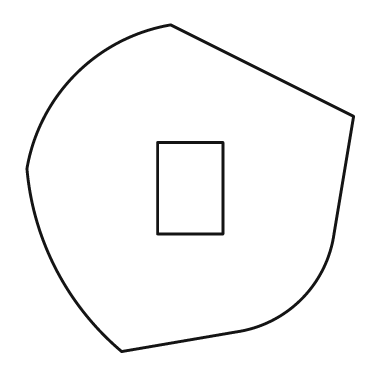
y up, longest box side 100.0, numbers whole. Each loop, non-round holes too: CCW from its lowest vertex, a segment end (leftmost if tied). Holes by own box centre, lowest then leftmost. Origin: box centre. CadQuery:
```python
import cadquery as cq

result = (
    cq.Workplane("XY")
    .moveTo(-21.0, -50.0)
    .lineTo(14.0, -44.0)
    .threePointArc((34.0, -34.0), (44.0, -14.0))
    .lineTo(50.0, 22.0)
    .lineTo(-6.0, 50.0)
    .threePointArc((-35.0, 35.0), (-50.0, 6.0))
    .threePointArc((-41.0, -25.0), (-21.0, -50.0))
    .close()
    .moveTo(-10.0, -14.0)
    .lineTo(10.0, -14.0)
    .lineTo(10.0, 14.0)
    .lineTo(-10.0, 14.0)
    .close()
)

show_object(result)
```